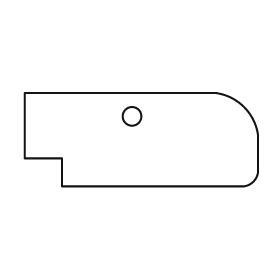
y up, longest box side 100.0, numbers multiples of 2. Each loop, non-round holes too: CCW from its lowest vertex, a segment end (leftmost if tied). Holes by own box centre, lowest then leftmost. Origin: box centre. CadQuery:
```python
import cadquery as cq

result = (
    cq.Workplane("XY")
    .moveTo(-34.0, -20.0)
    .lineTo(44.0, -20.0)
    .threePointArc((48.0, -18.0), (50.0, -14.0))
    .lineTo(50.0, 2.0)
    .threePointArc((44.0, 14.0), (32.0, 20.0))
    .lineTo(-50.0, 20.0)
    .lineTo(-50.0, -8.0)
    .lineTo(-34.0, -8.0)
    .close()
    .moveTo(-4.0, 10.0)
    .circle(4.0)
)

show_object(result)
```